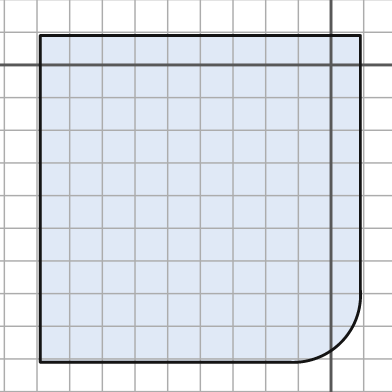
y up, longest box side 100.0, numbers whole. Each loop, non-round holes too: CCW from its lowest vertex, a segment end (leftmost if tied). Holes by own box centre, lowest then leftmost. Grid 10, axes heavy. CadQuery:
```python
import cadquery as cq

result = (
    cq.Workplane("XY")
    .moveTo(-89.0, -91.0)
    .lineTo(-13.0, -91.0)
    .threePointArc((3.0, -85.0), (9.0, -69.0))
    .lineTo(9.0, 9.0)
    .lineTo(-89.0, 9.0)
    .close()
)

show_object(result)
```